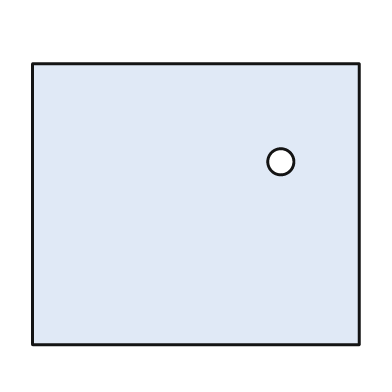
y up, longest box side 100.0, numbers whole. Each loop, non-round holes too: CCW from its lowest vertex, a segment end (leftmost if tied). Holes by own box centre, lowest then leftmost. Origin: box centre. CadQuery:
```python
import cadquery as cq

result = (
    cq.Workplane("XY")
    .moveTo(-50.0, -43.0)
    .lineTo(50.0, -43.0)
    .lineTo(50.0, 43.0)
    .lineTo(-50.0, 43.0)
    .close()
    .moveTo(26.0, 13.0)
    .circle(4.0)
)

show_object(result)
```